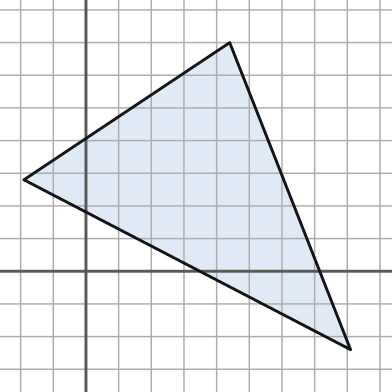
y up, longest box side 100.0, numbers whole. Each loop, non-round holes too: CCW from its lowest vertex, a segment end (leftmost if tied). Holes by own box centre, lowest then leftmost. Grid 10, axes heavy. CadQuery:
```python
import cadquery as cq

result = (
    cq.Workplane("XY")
    .moveTo(81.0, -24.0)
    .lineTo(44.0, 70.0)
    .lineTo(-19.0, 28.0)
    .close()
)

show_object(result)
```